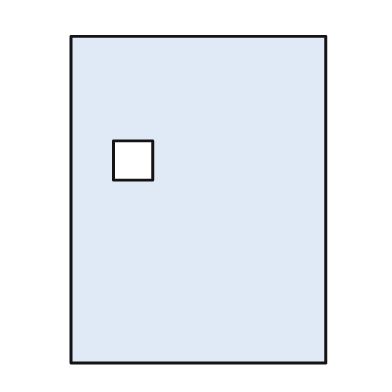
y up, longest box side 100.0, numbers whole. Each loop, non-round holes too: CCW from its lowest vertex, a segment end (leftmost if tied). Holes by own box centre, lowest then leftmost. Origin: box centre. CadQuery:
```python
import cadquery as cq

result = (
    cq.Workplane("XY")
    .moveTo(-39.0, -50.0)
    .lineTo(39.0, -50.0)
    .lineTo(39.0, 50.0)
    .lineTo(-39.0, 50.0)
    .close()
    .moveTo(-26.0, 6.0)
    .lineTo(-14.0, 6.0)
    .lineTo(-14.0, 18.0)
    .lineTo(-26.0, 18.0)
    .close()
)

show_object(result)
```